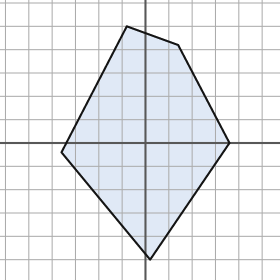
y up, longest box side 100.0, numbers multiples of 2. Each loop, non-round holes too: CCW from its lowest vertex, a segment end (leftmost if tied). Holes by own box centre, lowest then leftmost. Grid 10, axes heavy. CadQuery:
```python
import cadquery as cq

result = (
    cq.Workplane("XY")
    .moveTo(2.0, -50.0)
    .lineTo(36.0, 0.0)
    .lineTo(14.0, 42.0)
    .lineTo(-8.0, 50.0)
    .lineTo(-36.0, -4.0)
    .close()
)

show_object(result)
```